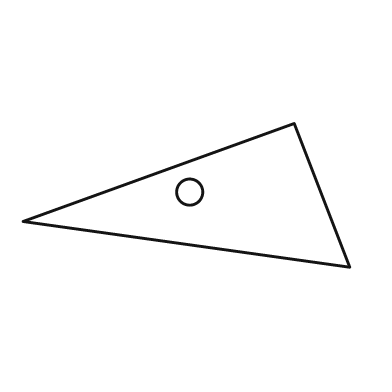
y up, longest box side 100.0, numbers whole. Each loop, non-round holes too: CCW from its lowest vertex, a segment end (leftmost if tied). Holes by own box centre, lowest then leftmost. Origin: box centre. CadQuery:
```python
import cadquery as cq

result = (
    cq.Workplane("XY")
    .moveTo(50.0, -22.0)
    .lineTo(33.0, 22.0)
    .lineTo(-50.0, -8.0)
    .close()
    .moveTo(1.0, 1.0)
    .circle(4.0)
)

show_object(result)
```